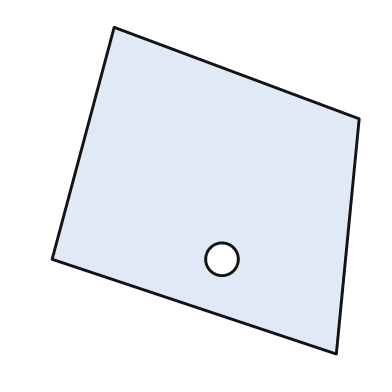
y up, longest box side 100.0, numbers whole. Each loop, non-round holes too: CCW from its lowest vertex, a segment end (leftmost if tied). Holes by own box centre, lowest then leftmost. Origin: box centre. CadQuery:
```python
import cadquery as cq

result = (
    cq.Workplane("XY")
    .moveTo(40.0, -50.0)
    .lineTo(47.0, 22.0)
    .lineTo(-28.0, 50.0)
    .lineTo(-47.0, -21.0)
    .close()
    .moveTo(5.0, -21.0)
    .circle(5.0)
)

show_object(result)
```